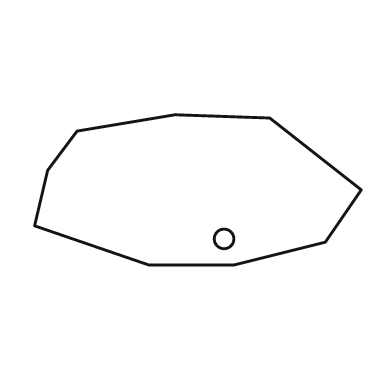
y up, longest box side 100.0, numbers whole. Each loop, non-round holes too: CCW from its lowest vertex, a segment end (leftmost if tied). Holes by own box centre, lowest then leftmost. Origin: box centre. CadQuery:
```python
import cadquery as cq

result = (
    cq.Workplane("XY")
    .moveTo(-15.0, -23.0)
    .lineTo(11.0, -23.0)
    .lineTo(39.0, -16.0)
    .lineTo(50.0, 0.0)
    .lineTo(22.0, 22.0)
    .lineTo(-7.0, 23.0)
    .lineTo(-37.0, 18.0)
    .lineTo(-46.0, 6.0)
    .lineTo(-50.0, -11.0)
    .close()
    .moveTo(8.0, -15.0)
    .circle(3.0)
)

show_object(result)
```